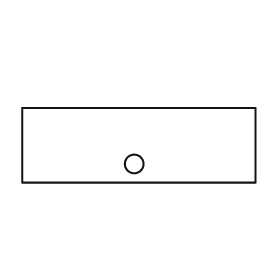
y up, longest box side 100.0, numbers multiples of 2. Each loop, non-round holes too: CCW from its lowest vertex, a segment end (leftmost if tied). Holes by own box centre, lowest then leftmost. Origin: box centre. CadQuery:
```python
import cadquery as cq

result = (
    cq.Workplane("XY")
    .moveTo(-50.0, -16.0)
    .lineTo(50.0, -16.0)
    .lineTo(50.0, 16.0)
    .lineTo(-50.0, 16.0)
    .close()
    .moveTo(-2.0, -8.0)
    .circle(4.0)
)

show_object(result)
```